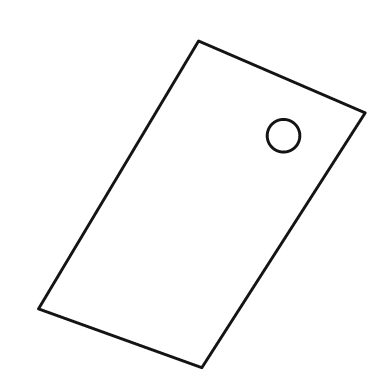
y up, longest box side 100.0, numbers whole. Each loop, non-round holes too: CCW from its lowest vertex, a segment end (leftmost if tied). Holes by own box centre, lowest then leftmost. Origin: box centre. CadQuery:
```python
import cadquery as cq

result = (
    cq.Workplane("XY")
    .moveTo(0.0, -50.0)
    .lineTo(50.0, 28.0)
    .lineTo(-1.0, 50.0)
    .lineTo(-50.0, -32.0)
    .close()
    .moveTo(25.0, 21.0)
    .circle(5.0)
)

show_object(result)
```